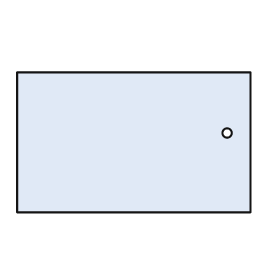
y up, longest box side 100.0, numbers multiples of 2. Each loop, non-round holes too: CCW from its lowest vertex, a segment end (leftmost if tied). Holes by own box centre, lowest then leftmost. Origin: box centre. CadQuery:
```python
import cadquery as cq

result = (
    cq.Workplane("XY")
    .moveTo(-50.0, -30.0)
    .lineTo(50.0, -30.0)
    .lineTo(50.0, 30.0)
    .lineTo(-50.0, 30.0)
    .close()
    .moveTo(40.0, 4.0)
    .circle(2.0)
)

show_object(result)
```